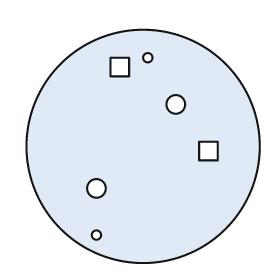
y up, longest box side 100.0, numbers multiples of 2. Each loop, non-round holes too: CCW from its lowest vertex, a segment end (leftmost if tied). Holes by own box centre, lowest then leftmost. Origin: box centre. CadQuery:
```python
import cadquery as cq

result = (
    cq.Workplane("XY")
    .moveTo(0.0, 0.0)
    .circle(50.0)
    .moveTo(-20.0, -38.0)
    .circle(2.0)
    .moveTo(-20.0, -18.0)
    .circle(4.0)
    .moveTo(24.0, -6.0)
    .lineTo(32.0, -6.0)
    .lineTo(32.0, 2.0)
    .lineTo(24.0, 2.0)
    .close()
    .moveTo(14.0, 18.0)
    .circle(4.0)
    .moveTo(-14.0, 30.0)
    .lineTo(-6.0, 30.0)
    .lineTo(-6.0, 38.0)
    .lineTo(-14.0, 38.0)
    .close()
    .moveTo(2.0, 38.0)
    .circle(2.0)
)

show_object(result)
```